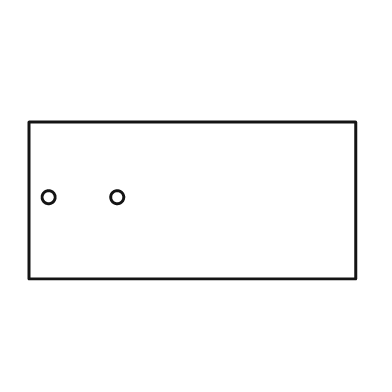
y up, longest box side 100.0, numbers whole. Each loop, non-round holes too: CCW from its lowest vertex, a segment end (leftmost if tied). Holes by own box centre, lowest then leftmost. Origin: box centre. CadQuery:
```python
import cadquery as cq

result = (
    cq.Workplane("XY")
    .moveTo(-50.0, -24.0)
    .lineTo(50.0, -24.0)
    .lineTo(50.0, 24.0)
    .lineTo(-50.0, 24.0)
    .close()
    .moveTo(-44.0, 1.0)
    .circle(2.0)
    .moveTo(-23.0, 1.0)
    .circle(2.0)
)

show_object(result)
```